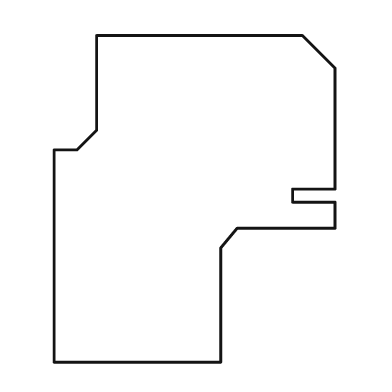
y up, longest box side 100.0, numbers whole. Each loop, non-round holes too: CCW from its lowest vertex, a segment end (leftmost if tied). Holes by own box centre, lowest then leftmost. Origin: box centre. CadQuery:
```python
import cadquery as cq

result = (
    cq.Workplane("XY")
    .moveTo(-43.0, -50.0)
    .lineTo(8.0, -50.0)
    .lineTo(8.0, -15.0)
    .lineTo(13.0, -9.0)
    .lineTo(43.0, -9.0)
    .lineTo(43.0, -1.0)
    .lineTo(30.0, -1.0)
    .lineTo(30.0, 3.0)
    .lineTo(43.0, 3.0)
    .lineTo(43.0, 40.0)
    .lineTo(33.0, 50.0)
    .lineTo(-30.0, 50.0)
    .lineTo(-30.0, 21.0)
    .lineTo(-36.0, 15.0)
    .lineTo(-43.0, 15.0)
    .close()
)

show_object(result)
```